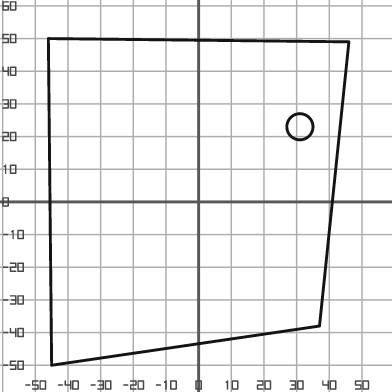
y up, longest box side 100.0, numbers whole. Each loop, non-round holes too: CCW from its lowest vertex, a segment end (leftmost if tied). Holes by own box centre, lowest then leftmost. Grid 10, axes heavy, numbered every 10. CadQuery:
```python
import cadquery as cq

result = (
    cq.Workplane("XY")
    .moveTo(-45.0, -50.0)
    .lineTo(37.0, -38.0)
    .lineTo(46.0, 49.0)
    .lineTo(-46.0, 50.0)
    .close()
    .moveTo(31.0, 23.0)
    .circle(4.0)
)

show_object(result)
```